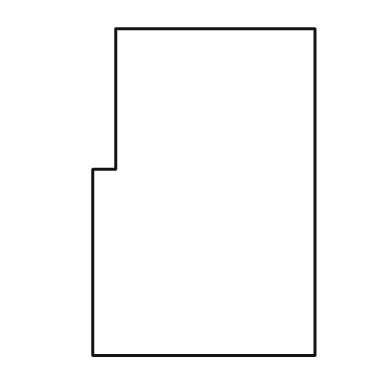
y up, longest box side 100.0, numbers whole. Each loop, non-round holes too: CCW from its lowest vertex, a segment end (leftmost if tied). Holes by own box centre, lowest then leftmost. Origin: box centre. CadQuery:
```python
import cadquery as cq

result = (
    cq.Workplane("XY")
    .moveTo(-34.0, -50.0)
    .lineTo(34.0, -50.0)
    .lineTo(34.0, 50.0)
    .lineTo(-27.0, 50.0)
    .lineTo(-27.0, 7.0)
    .lineTo(-34.0, 7.0)
    .close()
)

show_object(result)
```